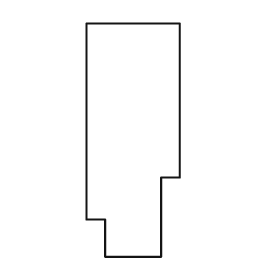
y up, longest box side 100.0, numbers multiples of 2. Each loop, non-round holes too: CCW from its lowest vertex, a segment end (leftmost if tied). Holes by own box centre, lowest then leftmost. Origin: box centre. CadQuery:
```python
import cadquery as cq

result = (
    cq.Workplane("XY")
    .moveTo(-12.0, -50.0)
    .lineTo(12.0, -50.0)
    .lineTo(12.0, -16.0)
    .lineTo(20.0, -16.0)
    .lineTo(20.0, 50.0)
    .lineTo(-20.0, 50.0)
    .lineTo(-20.0, -34.0)
    .lineTo(-12.0, -34.0)
    .close()
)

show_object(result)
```